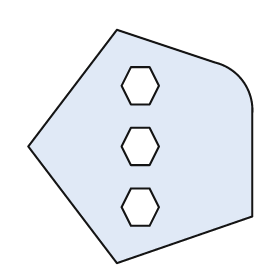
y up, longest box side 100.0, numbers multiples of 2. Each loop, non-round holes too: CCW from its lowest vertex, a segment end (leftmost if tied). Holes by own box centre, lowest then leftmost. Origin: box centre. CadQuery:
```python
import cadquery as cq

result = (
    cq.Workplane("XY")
    .moveTo(-10.0, -50.0)
    .lineTo(48.0, -30.0)
    .lineTo(48.0, 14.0)
    .threePointArc((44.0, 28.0), (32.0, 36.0))
    .lineTo(-10.0, 50.0)
    .lineTo(-48.0, 0.0)
    .close()
    .moveTo(-4.0, -34.0)
    .lineTo(4.0, -34.0)
    .lineTo(8.0, -26.0)
    .lineTo(4.0, -18.0)
    .lineTo(-4.0, -18.0)
    .lineTo(-8.0, -26.0)
    .close()
    .moveTo(-4.0, -8.0)
    .lineTo(4.0, -8.0)
    .lineTo(8.0, 0.0)
    .lineTo(4.0, 8.0)
    .lineTo(-4.0, 8.0)
    .lineTo(-8.0, 0.0)
    .close()
    .moveTo(-4.0, 18.0)
    .lineTo(4.0, 18.0)
    .lineTo(8.0, 26.0)
    .lineTo(4.0, 34.0)
    .lineTo(-4.0, 34.0)
    .lineTo(-8.0, 26.0)
    .close()
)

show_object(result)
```